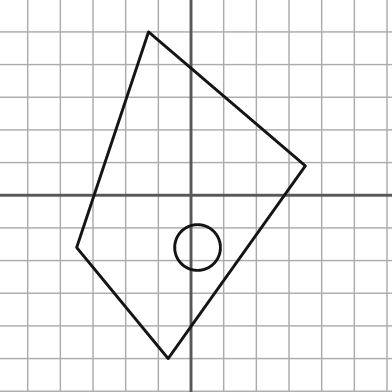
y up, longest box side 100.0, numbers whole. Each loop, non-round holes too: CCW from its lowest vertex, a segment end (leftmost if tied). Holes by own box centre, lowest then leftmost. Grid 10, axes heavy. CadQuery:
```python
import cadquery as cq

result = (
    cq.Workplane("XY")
    .moveTo(-7.0, -50.0)
    .lineTo(35.0, 9.0)
    .lineTo(-13.0, 50.0)
    .lineTo(-35.0, -16.0)
    .close()
    .moveTo(2.0, -16.0)
    .circle(7.0)
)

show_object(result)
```